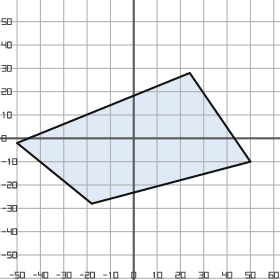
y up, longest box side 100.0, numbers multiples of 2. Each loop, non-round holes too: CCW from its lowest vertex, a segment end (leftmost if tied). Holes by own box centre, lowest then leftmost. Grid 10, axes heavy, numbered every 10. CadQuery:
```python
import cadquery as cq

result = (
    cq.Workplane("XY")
    .moveTo(-18.0, -28.0)
    .lineTo(50.0, -10.0)
    .lineTo(24.0, 28.0)
    .lineTo(-50.0, -2.0)
    .close()
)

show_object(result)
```